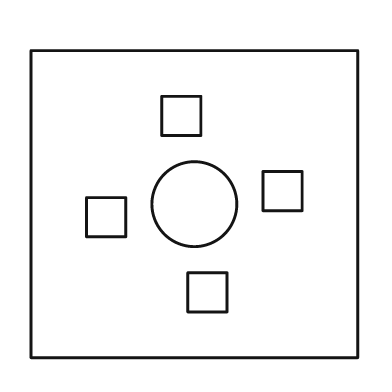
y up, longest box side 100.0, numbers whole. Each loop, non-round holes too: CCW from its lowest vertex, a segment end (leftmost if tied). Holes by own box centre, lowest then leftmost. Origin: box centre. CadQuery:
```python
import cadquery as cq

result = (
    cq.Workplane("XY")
    .moveTo(-50.0, -47.0)
    .lineTo(50.0, -47.0)
    .lineTo(50.0, 47.0)
    .lineTo(-50.0, 47.0)
    .close()
    .moveTo(-2.0, -33.0)
    .lineTo(10.0, -33.0)
    .lineTo(10.0, -21.0)
    .lineTo(-2.0, -21.0)
    .close()
    .moveTo(-33.0, -10.0)
    .lineTo(-21.0, -10.0)
    .lineTo(-21.0, 2.0)
    .lineTo(-33.0, 2.0)
    .close()
    .moveTo(0.0, 0.0)
    .circle(13.0)
    .moveTo(21.0, -2.0)
    .lineTo(33.0, -2.0)
    .lineTo(33.0, 10.0)
    .lineTo(21.0, 10.0)
    .close()
    .moveTo(-10.0, 21.0)
    .lineTo(2.0, 21.0)
    .lineTo(2.0, 33.0)
    .lineTo(-10.0, 33.0)
    .close()
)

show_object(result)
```